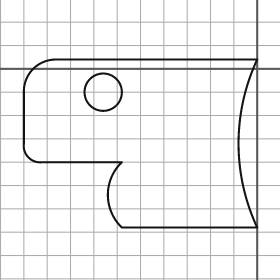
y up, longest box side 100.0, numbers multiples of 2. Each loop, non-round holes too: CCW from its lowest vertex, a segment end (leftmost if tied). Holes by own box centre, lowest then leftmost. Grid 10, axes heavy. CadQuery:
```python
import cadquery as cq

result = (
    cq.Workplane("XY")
    .moveTo(-58.0, -68.0)
    .lineTo(0.0, -68.0)
    .threePointArc((-8.0, -32.0), (0.0, 4.0))
    .lineTo(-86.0, 4.0)
    .threePointArc((-96.0, 0.0), (-100.0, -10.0))
    .lineTo(-100.0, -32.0)
    .threePointArc((-98.0, -38.0), (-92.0, -40.0))
    .lineTo(-58.0, -40.0)
    .threePointArc((-64.0, -54.0), (-58.0, -68.0))
    .close()
    .moveTo(-66.0, -10.0)
    .circle(8.0)
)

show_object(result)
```